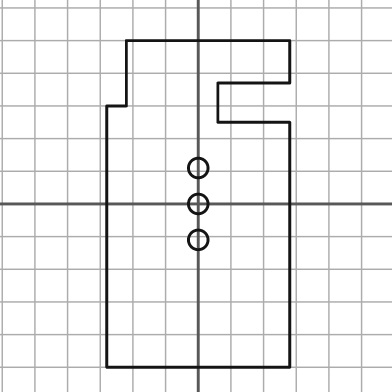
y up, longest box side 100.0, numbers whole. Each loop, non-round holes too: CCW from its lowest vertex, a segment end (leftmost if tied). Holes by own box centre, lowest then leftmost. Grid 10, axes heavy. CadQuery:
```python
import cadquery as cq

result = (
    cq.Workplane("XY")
    .moveTo(-28.0, -50.0)
    .lineTo(28.0, -50.0)
    .lineTo(28.0, 25.0)
    .lineTo(6.0, 25.0)
    .lineTo(6.0, 37.0)
    .lineTo(28.0, 37.0)
    .lineTo(28.0, 50.0)
    .lineTo(-22.0, 50.0)
    .lineTo(-22.0, 30.0)
    .lineTo(-28.0, 30.0)
    .close()
    .moveTo(0.0, -11.0)
    .circle(3.0)
    .moveTo(0.0, 0.0)
    .circle(3.0)
    .moveTo(0.0, 11.0)
    .circle(3.0)
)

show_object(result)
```